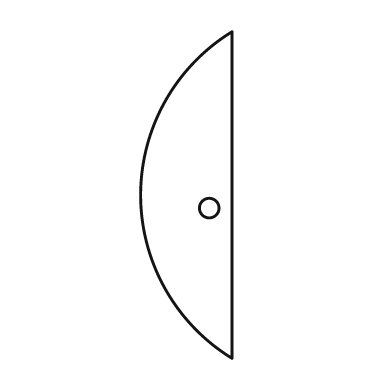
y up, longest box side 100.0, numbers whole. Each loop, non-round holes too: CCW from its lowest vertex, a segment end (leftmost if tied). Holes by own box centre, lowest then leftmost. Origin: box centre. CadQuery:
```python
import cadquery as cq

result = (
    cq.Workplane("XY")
    .moveTo(14.0, -50.0)
    .lineTo(14.0, 50.0)
    .threePointArc((-14.0, 0.0), (14.0, -50.0))
    .close()
    .moveTo(7.0, -4.0)
    .circle(3.0)
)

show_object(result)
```